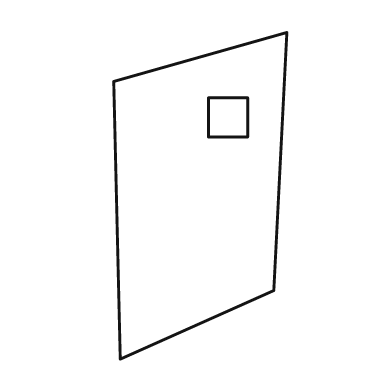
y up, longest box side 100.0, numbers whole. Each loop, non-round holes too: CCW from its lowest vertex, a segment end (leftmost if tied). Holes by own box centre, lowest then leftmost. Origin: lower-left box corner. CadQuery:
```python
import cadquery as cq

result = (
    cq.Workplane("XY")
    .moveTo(2.0, 0.0)
    .lineTo(49.0, 21.0)
    .lineTo(53.0, 100.0)
    .lineTo(0.0, 85.0)
    .close()
    .moveTo(29.0, 68.0)
    .lineTo(41.0, 68.0)
    .lineTo(41.0, 80.0)
    .lineTo(29.0, 80.0)
    .close()
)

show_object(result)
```